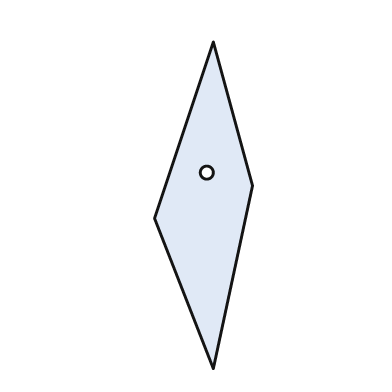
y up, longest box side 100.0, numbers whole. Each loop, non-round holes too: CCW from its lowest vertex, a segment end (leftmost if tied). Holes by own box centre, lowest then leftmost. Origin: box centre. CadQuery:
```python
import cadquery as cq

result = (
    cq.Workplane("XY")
    .moveTo(3.0, -50.0)
    .lineTo(15.0, 6.0)
    .lineTo(3.0, 50.0)
    .lineTo(-15.0, -4.0)
    .close()
    .moveTo(1.0, 10.0)
    .circle(2.0)
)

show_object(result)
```